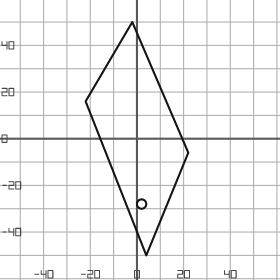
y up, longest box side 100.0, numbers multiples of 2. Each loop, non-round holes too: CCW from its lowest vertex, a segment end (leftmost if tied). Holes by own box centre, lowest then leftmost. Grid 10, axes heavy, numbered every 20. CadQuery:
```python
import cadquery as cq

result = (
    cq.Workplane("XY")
    .moveTo(4.0, -50.0)
    .lineTo(22.0, -6.0)
    .lineTo(-2.0, 50.0)
    .lineTo(-22.0, 16.0)
    .close()
    .moveTo(2.0, -28.0)
    .circle(2.0)
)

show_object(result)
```